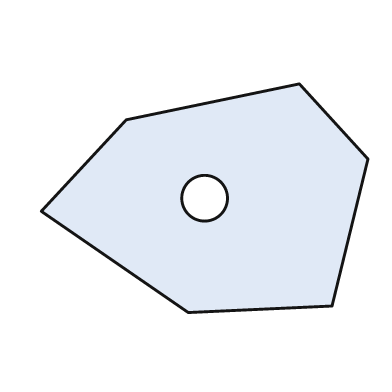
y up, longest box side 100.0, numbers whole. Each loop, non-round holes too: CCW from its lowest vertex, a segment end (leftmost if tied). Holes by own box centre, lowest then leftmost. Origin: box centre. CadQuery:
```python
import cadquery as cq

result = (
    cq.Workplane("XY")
    .moveTo(-5.0, -35.0)
    .lineTo(39.0, -33.0)
    .lineTo(50.0, 12.0)
    .lineTo(29.0, 35.0)
    .lineTo(-24.0, 24.0)
    .lineTo(-50.0, -4.0)
    .close()
    .moveTo(0.0, 0.0)
    .circle(7.0)
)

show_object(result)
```